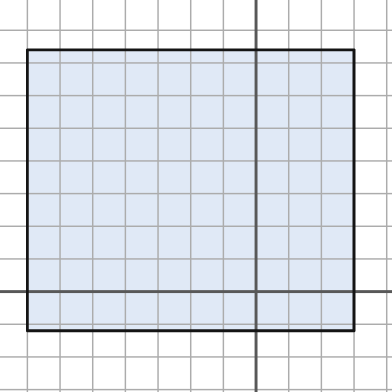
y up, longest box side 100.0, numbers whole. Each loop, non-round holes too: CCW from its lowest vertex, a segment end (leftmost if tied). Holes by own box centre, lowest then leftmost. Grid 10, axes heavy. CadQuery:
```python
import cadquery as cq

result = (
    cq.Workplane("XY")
    .moveTo(-70.0, -12.0)
    .lineTo(30.0, -12.0)
    .lineTo(30.0, 74.0)
    .lineTo(-70.0, 74.0)
    .close()
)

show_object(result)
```